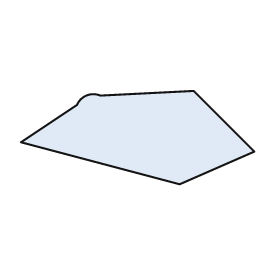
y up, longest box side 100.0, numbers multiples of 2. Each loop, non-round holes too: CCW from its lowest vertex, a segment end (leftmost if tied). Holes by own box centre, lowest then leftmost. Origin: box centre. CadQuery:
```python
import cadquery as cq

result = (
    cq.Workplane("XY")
    .moveTo(18.0, -20.0)
    .lineTo(50.0, -6.0)
    .lineTo(24.0, 20.0)
    .lineTo(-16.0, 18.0)
    .threePointArc((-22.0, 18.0), (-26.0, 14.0))
    .lineTo(-50.0, -2.0)
    .close()
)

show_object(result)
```